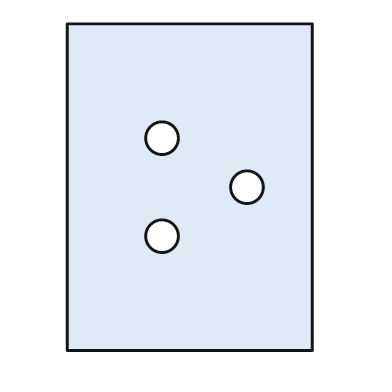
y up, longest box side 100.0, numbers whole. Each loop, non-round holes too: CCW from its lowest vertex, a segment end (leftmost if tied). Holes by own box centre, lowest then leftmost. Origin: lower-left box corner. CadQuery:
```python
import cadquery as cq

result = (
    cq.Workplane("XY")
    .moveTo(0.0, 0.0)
    .lineTo(75.0, 0.0)
    .lineTo(75.0, 100.0)
    .lineTo(0.0, 100.0)
    .close()
    .moveTo(29.0, 35.0)
    .circle(5.0)
    .moveTo(55.0, 50.0)
    .circle(5.0)
    .moveTo(29.0, 65.0)
    .circle(5.0)
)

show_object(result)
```